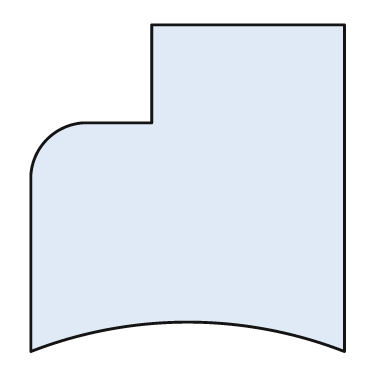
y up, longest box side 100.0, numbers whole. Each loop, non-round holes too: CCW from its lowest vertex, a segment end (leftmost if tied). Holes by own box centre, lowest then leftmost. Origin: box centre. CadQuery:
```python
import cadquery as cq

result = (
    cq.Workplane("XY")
    .moveTo(-48.0, -50.0)
    .threePointArc((0.0, -41.0), (48.0, -50.0))
    .lineTo(48.0, 50.0)
    .lineTo(-11.0, 50.0)
    .lineTo(-11.0, 20.0)
    .lineTo(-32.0, 20.0)
    .threePointArc((-43.0, 15.0), (-48.0, 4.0))
    .close()
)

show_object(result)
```